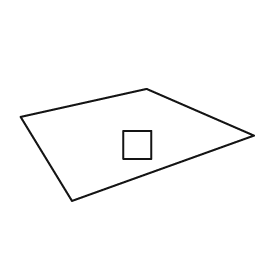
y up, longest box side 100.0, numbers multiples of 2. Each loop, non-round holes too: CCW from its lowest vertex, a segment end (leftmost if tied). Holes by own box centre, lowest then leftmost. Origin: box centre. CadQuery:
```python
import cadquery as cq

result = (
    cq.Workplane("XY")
    .moveTo(-28.0, -24.0)
    .lineTo(50.0, 4.0)
    .lineTo(4.0, 24.0)
    .lineTo(-50.0, 12.0)
    .close()
    .moveTo(-6.0, -6.0)
    .lineTo(6.0, -6.0)
    .lineTo(6.0, 6.0)
    .lineTo(-6.0, 6.0)
    .close()
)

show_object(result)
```